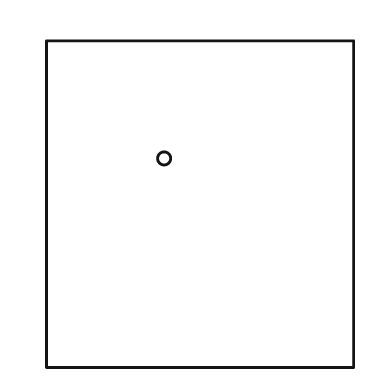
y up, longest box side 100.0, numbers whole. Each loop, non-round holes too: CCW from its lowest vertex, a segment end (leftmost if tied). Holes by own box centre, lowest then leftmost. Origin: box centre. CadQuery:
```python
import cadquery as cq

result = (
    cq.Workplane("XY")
    .moveTo(-47.0, -50.0)
    .lineTo(47.0, -50.0)
    .lineTo(47.0, 50.0)
    .lineTo(-47.0, 50.0)
    .close()
    .moveTo(-11.0, 14.0)
    .circle(2.0)
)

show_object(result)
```